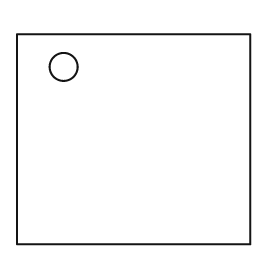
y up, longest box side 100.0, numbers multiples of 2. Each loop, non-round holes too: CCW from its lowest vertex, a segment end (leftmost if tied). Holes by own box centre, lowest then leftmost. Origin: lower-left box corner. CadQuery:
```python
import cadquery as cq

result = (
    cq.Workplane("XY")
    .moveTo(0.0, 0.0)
    .lineTo(100.0, 0.0)
    .lineTo(100.0, 90.0)
    .lineTo(0.0, 90.0)
    .close()
    .moveTo(20.0, 76.0)
    .circle(6.0)
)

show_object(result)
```